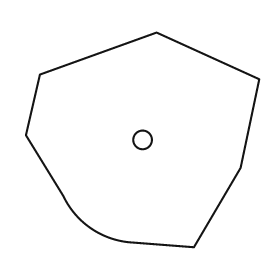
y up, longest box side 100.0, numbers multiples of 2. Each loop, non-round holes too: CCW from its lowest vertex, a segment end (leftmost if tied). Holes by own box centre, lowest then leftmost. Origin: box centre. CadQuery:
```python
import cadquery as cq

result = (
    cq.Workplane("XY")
    .moveTo(22.0, -46.0)
    .lineTo(42.0, -12.0)
    .lineTo(50.0, 26.0)
    .lineTo(6.0, 46.0)
    .lineTo(-44.0, 28.0)
    .lineTo(-50.0, 2.0)
    .lineTo(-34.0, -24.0)
    .threePointArc((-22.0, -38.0), (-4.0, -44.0))
    .close()
    .moveTo(0.0, 0.0)
    .circle(4.0)
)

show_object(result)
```